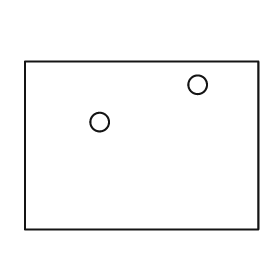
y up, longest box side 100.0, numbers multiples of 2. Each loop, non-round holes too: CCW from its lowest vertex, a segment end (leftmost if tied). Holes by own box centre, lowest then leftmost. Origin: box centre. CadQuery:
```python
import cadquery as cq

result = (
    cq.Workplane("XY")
    .moveTo(-50.0, -36.0)
    .lineTo(50.0, -36.0)
    .lineTo(50.0, 36.0)
    .lineTo(-50.0, 36.0)
    .close()
    .moveTo(-18.0, 10.0)
    .circle(4.0)
    .moveTo(24.0, 26.0)
    .circle(4.0)
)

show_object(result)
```